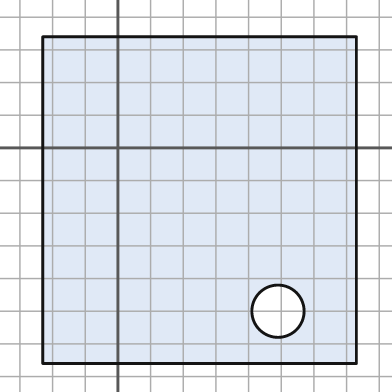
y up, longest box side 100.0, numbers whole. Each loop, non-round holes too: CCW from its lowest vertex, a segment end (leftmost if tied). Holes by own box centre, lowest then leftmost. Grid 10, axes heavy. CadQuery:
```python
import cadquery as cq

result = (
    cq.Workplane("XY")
    .moveTo(-23.0, -66.0)
    .lineTo(73.0, -66.0)
    .lineTo(73.0, 34.0)
    .lineTo(-23.0, 34.0)
    .close()
    .moveTo(49.0, -50.0)
    .circle(8.0)
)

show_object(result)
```